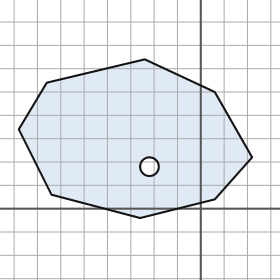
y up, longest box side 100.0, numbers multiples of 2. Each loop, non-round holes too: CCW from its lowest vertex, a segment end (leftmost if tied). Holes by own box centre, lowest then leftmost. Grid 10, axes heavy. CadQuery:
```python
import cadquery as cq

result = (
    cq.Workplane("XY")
    .moveTo(-26.0, -4.0)
    .lineTo(6.0, 4.0)
    .lineTo(22.0, 22.0)
    .lineTo(6.0, 50.0)
    .lineTo(-24.0, 64.0)
    .lineTo(-66.0, 54.0)
    .lineTo(-78.0, 34.0)
    .lineTo(-64.0, 6.0)
    .close()
    .moveTo(-22.0, 18.0)
    .circle(4.0)
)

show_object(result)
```